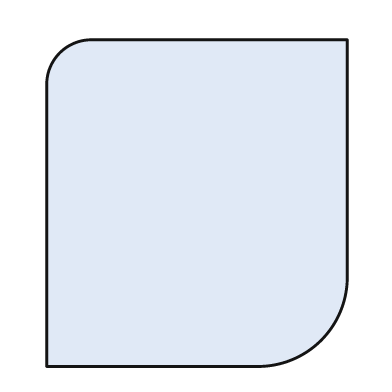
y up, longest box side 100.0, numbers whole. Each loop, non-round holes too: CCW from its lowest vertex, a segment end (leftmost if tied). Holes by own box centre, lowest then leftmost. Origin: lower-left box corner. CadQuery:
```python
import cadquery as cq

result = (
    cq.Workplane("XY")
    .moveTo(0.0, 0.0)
    .lineTo(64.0, 0.0)
    .threePointArc((84.0, 8.0), (92.0, 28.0))
    .lineTo(92.0, 100.0)
    .lineTo(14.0, 100.0)
    .threePointArc((4.0, 96.0), (0.0, 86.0))
    .close()
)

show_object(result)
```